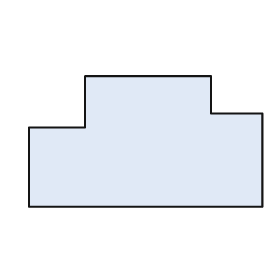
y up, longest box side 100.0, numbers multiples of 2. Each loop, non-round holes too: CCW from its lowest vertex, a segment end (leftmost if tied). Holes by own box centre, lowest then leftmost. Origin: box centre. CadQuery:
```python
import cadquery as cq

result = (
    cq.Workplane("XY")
    .moveTo(-50.0, -28.0)
    .lineTo(50.0, -28.0)
    .lineTo(50.0, 12.0)
    .lineTo(28.0, 12.0)
    .lineTo(28.0, 28.0)
    .lineTo(-26.0, 28.0)
    .lineTo(-26.0, 6.0)
    .lineTo(-50.0, 6.0)
    .close()
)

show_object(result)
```